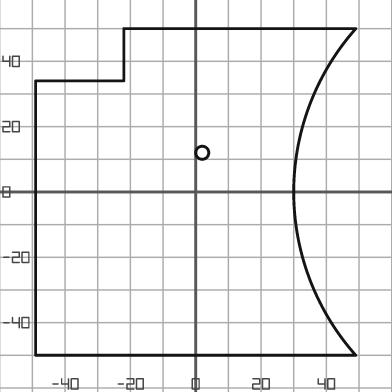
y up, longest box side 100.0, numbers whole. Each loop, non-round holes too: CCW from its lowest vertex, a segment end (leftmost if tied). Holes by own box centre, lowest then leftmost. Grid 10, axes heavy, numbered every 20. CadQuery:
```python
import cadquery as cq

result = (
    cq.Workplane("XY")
    .moveTo(-49.0, -50.0)
    .lineTo(49.0, -50.0)
    .threePointArc((30.0, 0.0), (49.0, 50.0))
    .lineTo(-22.0, 50.0)
    .lineTo(-22.0, 34.0)
    .lineTo(-49.0, 34.0)
    .close()
    .moveTo(2.0, 12.0)
    .circle(2.0)
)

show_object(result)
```